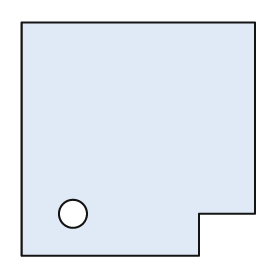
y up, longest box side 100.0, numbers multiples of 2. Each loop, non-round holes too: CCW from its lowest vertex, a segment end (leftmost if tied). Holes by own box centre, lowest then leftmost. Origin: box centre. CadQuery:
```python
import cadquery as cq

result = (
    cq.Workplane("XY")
    .moveTo(-50.0, -50.0)
    .lineTo(26.0, -50.0)
    .lineTo(26.0, -32.0)
    .lineTo(50.0, -32.0)
    .lineTo(50.0, 50.0)
    .lineTo(-50.0, 50.0)
    .close()
    .moveTo(-28.0, -32.0)
    .circle(6.0)
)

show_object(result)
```